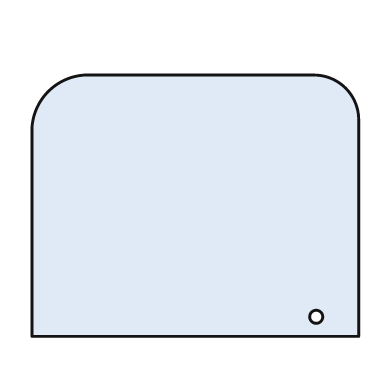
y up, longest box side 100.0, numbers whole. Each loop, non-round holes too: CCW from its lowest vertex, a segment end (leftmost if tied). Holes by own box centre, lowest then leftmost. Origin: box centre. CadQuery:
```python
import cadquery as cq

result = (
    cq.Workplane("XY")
    .moveTo(-50.0, -40.0)
    .lineTo(50.0, -40.0)
    .lineTo(50.0, 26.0)
    .threePointArc((46.0, 36.0), (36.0, 40.0))
    .lineTo(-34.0, 40.0)
    .threePointArc((-45.0, 35.0), (-50.0, 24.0))
    .close()
    .moveTo(37.0, -34.0)
    .circle(2.0)
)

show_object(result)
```